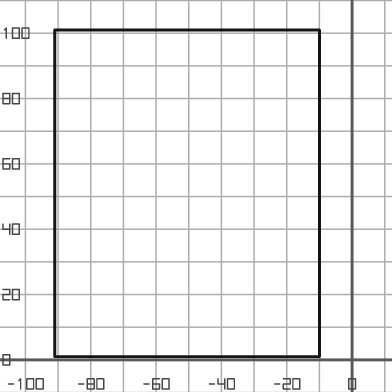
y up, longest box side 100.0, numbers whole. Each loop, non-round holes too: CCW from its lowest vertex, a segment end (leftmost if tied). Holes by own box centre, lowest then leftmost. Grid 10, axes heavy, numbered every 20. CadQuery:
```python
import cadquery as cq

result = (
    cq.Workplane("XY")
    .moveTo(-91.0, 1.0)
    .lineTo(-10.0, 1.0)
    .lineTo(-10.0, 101.0)
    .lineTo(-91.0, 101.0)
    .close()
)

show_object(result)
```